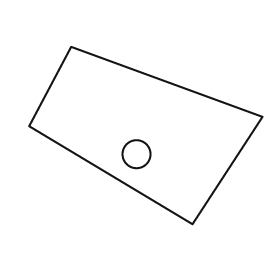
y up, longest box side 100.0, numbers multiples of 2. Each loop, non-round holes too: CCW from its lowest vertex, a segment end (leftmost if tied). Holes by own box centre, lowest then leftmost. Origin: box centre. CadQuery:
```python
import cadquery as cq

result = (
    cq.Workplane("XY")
    .moveTo(20.0, -38.0)
    .lineTo(50.0, 8.0)
    .lineTo(-32.0, 38.0)
    .lineTo(-50.0, 4.0)
    .close()
    .moveTo(-4.0, -8.0)
    .circle(6.0)
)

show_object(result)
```